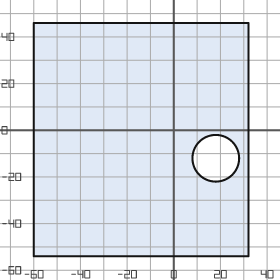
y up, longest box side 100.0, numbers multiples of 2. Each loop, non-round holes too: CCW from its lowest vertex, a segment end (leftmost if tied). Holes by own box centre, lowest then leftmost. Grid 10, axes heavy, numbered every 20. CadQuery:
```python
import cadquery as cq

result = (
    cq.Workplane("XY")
    .moveTo(-60.0, -54.0)
    .lineTo(32.0, -54.0)
    .lineTo(32.0, 46.0)
    .lineTo(-60.0, 46.0)
    .close()
    .moveTo(18.0, -12.0)
    .circle(10.0)
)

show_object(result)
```